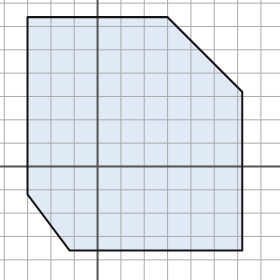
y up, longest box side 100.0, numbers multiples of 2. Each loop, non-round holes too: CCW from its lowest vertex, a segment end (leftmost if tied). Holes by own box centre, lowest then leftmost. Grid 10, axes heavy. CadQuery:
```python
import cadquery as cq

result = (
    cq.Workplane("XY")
    .moveTo(-12.0, -36.0)
    .lineTo(62.0, -36.0)
    .lineTo(62.0, 32.0)
    .lineTo(30.0, 64.0)
    .lineTo(-30.0, 64.0)
    .lineTo(-30.0, -12.0)
    .close()
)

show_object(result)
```